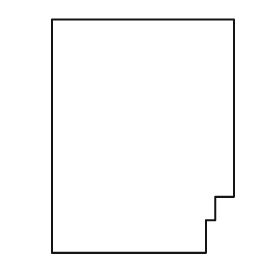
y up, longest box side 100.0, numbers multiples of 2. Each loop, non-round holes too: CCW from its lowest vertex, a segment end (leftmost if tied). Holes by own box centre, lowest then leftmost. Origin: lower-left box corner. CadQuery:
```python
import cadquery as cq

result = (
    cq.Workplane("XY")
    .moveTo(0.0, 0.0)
    .lineTo(66.0, 0.0)
    .lineTo(66.0, 14.0)
    .lineTo(70.0, 14.0)
    .lineTo(70.0, 24.0)
    .lineTo(78.0, 24.0)
    .lineTo(78.0, 100.0)
    .lineTo(0.0, 100.0)
    .close()
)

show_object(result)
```